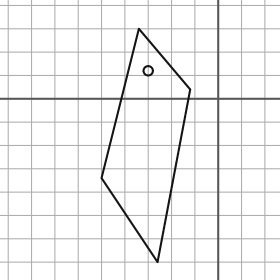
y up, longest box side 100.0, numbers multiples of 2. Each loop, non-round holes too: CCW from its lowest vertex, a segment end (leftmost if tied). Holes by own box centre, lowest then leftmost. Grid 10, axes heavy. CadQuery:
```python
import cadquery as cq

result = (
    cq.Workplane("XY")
    .moveTo(-26.0, -70.0)
    .lineTo(-12.0, 4.0)
    .lineTo(-34.0, 30.0)
    .lineTo(-50.0, -34.0)
    .close()
    .moveTo(-30.0, 12.0)
    .circle(2.0)
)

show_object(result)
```